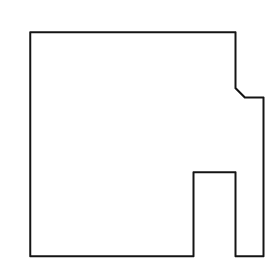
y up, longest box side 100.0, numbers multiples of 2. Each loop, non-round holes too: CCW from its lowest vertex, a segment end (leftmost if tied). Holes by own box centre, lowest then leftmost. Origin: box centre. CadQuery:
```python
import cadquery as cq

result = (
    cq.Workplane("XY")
    .moveTo(-50.0, -48.0)
    .lineTo(20.0, -48.0)
    .lineTo(20.0, -12.0)
    .lineTo(38.0, -12.0)
    .lineTo(38.0, -48.0)
    .lineTo(50.0, -48.0)
    .lineTo(50.0, 20.0)
    .lineTo(42.0, 20.0)
    .lineTo(38.0, 24.0)
    .lineTo(38.0, 48.0)
    .lineTo(-50.0, 48.0)
    .close()
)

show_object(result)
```